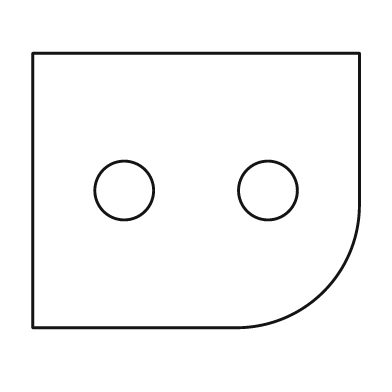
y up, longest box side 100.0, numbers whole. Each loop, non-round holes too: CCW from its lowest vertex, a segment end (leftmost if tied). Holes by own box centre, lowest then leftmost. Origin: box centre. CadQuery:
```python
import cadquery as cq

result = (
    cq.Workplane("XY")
    .moveTo(-50.0, -42.0)
    .lineTo(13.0, -42.0)
    .threePointArc((39.0, -31.0), (50.0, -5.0))
    .lineTo(50.0, 42.0)
    .lineTo(-50.0, 42.0)
    .close()
    .moveTo(-22.0, 0.0)
    .circle(9.0)
    .moveTo(22.0, 0.0)
    .circle(9.0)
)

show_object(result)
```